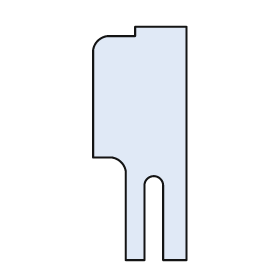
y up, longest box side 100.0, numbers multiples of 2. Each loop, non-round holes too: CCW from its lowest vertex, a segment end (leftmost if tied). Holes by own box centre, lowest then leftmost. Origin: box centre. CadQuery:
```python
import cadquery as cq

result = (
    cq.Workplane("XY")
    .moveTo(-6.0, -50.0)
    .lineTo(2.0, -50.0)
    .lineTo(2.0, -18.0)
    .threePointArc((6.0, -14.0), (10.0, -18.0))
    .lineTo(10.0, -50.0)
    .lineTo(20.0, -50.0)
    .lineTo(20.0, 50.0)
    .lineTo(-2.0, 50.0)
    .lineTo(-2.0, 46.0)
    .lineTo(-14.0, 46.0)
    .threePointArc((-18.0, 44.0), (-20.0, 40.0))
    .lineTo(-20.0, -6.0)
    .lineTo(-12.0, -6.0)
    .threePointArc((-8.0, -8.0), (-6.0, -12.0))
    .close()
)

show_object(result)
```